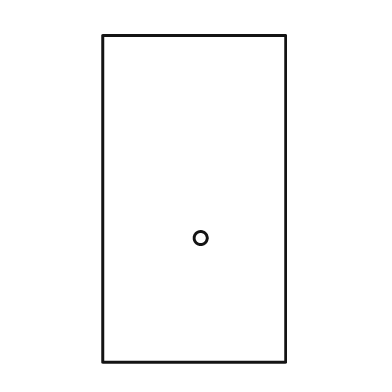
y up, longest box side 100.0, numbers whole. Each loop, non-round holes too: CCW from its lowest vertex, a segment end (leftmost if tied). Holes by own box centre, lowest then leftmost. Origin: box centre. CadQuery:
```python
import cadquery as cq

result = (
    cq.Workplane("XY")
    .moveTo(-28.0, -50.0)
    .lineTo(28.0, -50.0)
    .lineTo(28.0, 50.0)
    .lineTo(-28.0, 50.0)
    .close()
    .moveTo(2.0, -12.0)
    .circle(2.0)
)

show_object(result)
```